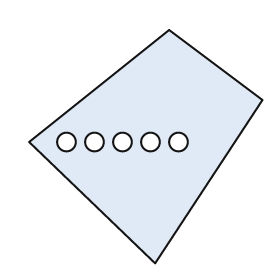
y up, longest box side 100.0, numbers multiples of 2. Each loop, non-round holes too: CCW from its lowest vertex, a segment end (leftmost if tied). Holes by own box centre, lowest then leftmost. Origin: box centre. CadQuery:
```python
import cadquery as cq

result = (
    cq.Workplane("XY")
    .moveTo(4.0, -50.0)
    .lineTo(50.0, 20.0)
    .lineTo(10.0, 50.0)
    .lineTo(-50.0, 2.0)
    .close()
    .moveTo(-34.0, 2.0)
    .circle(4.0)
    .moveTo(-22.0, 2.0)
    .circle(4.0)
    .moveTo(-10.0, 2.0)
    .circle(4.0)
    .moveTo(2.0, 2.0)
    .circle(4.0)
    .moveTo(14.0, 2.0)
    .circle(4.0)
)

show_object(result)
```